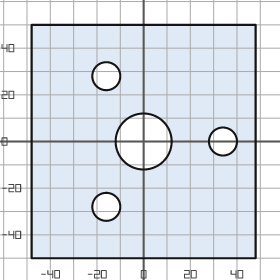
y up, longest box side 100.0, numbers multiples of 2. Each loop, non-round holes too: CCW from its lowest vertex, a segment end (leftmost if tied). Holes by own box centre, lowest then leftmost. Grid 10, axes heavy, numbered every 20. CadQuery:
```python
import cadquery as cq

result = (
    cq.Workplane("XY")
    .moveTo(-48.0, -50.0)
    .lineTo(48.0, -50.0)
    .lineTo(48.0, 50.0)
    .lineTo(-48.0, 50.0)
    .close()
    .moveTo(-16.0, -28.0)
    .circle(6.0)
    .moveTo(0.0, 0.0)
    .circle(12.0)
    .moveTo(34.0, 0.0)
    .circle(6.0)
    .moveTo(-16.0, 28.0)
    .circle(6.0)
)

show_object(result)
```